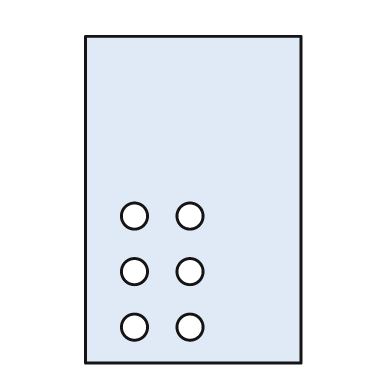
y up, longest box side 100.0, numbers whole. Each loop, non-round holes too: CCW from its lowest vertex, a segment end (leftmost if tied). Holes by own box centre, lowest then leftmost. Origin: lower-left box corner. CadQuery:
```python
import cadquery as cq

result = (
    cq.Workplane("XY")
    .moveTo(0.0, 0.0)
    .lineTo(66.0, 0.0)
    .lineTo(66.0, 100.0)
    .lineTo(0.0, 100.0)
    .close()
    .moveTo(15.0, 11.0)
    .circle(4.0)
    .moveTo(32.0, 11.0)
    .circle(4.0)
    .moveTo(15.0, 28.0)
    .circle(4.0)
    .moveTo(32.0, 28.0)
    .circle(4.0)
    .moveTo(15.0, 45.0)
    .circle(4.0)
    .moveTo(32.0, 45.0)
    .circle(4.0)
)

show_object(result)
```